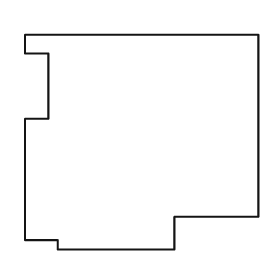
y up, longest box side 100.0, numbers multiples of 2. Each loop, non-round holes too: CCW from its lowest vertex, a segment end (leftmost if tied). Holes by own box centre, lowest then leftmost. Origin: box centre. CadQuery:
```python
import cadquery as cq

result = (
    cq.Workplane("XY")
    .moveTo(-36.0, -46.0)
    .lineTo(14.0, -46.0)
    .lineTo(14.0, -32.0)
    .lineTo(50.0, -32.0)
    .lineTo(50.0, 46.0)
    .lineTo(-50.0, 46.0)
    .lineTo(-50.0, 38.0)
    .lineTo(-40.0, 38.0)
    .lineTo(-40.0, 10.0)
    .lineTo(-50.0, 10.0)
    .lineTo(-50.0, -42.0)
    .lineTo(-36.0, -42.0)
    .close()
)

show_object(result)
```